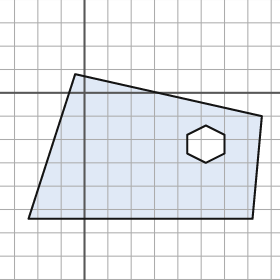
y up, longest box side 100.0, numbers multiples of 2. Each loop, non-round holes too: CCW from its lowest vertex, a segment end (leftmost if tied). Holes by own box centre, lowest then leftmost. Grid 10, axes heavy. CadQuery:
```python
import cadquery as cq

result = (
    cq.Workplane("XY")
    .moveTo(-24.0, -54.0)
    .lineTo(72.0, -54.0)
    .lineTo(76.0, -10.0)
    .lineTo(-4.0, 8.0)
    .close()
    .moveTo(52.0, -30.0)
    .lineTo(60.0, -26.0)
    .lineTo(60.0, -18.0)
    .lineTo(52.0, -14.0)
    .lineTo(44.0, -18.0)
    .lineTo(44.0, -26.0)
    .close()
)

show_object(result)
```